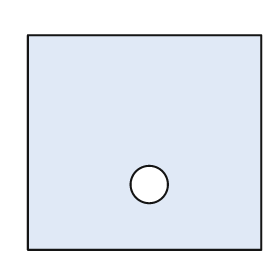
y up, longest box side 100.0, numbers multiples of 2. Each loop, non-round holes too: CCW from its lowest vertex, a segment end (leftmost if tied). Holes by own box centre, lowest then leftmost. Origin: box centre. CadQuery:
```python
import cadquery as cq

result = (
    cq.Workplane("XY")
    .moveTo(-50.0, -46.0)
    .lineTo(50.0, -46.0)
    .lineTo(50.0, 46.0)
    .lineTo(-50.0, 46.0)
    .close()
    .moveTo(2.0, -18.0)
    .circle(8.0)
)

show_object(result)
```